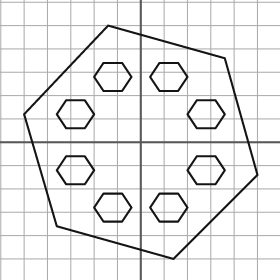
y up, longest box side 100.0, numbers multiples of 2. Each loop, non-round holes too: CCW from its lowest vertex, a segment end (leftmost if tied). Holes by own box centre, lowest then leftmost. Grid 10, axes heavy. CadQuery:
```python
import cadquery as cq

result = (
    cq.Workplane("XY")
    .moveTo(14.0, -50.0)
    .lineTo(50.0, -14.0)
    .lineTo(36.0, 36.0)
    .lineTo(-14.0, 50.0)
    .lineTo(-50.0, 12.0)
    .lineTo(-36.0, -36.0)
    .close()
    .moveTo(-16.0, -34.0)
    .lineTo(-8.0, -34.0)
    .lineTo(-4.0, -28.0)
    .lineTo(-8.0, -22.0)
    .lineTo(-16.0, -22.0)
    .lineTo(-20.0, -28.0)
    .close()
    .moveTo(8.0, -34.0)
    .lineTo(16.0, -34.0)
    .lineTo(20.0, -28.0)
    .lineTo(16.0, -22.0)
    .lineTo(8.0, -22.0)
    .lineTo(4.0, -28.0)
    .close()
    .moveTo(-32.0, -18.0)
    .lineTo(-24.0, -18.0)
    .lineTo(-20.0, -12.0)
    .lineTo(-24.0, -6.0)
    .lineTo(-32.0, -6.0)
    .lineTo(-36.0, -12.0)
    .close()
    .moveTo(24.0, -18.0)
    .lineTo(32.0, -18.0)
    .lineTo(36.0, -12.0)
    .lineTo(32.0, -6.0)
    .lineTo(24.0, -6.0)
    .lineTo(20.0, -12.0)
    .close()
    .moveTo(-32.0, 6.0)
    .lineTo(-24.0, 6.0)
    .lineTo(-20.0, 12.0)
    .lineTo(-24.0, 18.0)
    .lineTo(-32.0, 18.0)
    .lineTo(-36.0, 12.0)
    .close()
    .moveTo(24.0, 6.0)
    .lineTo(32.0, 6.0)
    .lineTo(36.0, 12.0)
    .lineTo(32.0, 18.0)
    .lineTo(24.0, 18.0)
    .lineTo(20.0, 12.0)
    .close()
    .moveTo(-16.0, 22.0)
    .lineTo(-8.0, 22.0)
    .lineTo(-4.0, 28.0)
    .lineTo(-8.0, 34.0)
    .lineTo(-16.0, 34.0)
    .lineTo(-20.0, 28.0)
    .close()
    .moveTo(8.0, 22.0)
    .lineTo(16.0, 22.0)
    .lineTo(20.0, 28.0)
    .lineTo(16.0, 34.0)
    .lineTo(8.0, 34.0)
    .lineTo(4.0, 28.0)
    .close()
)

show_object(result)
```